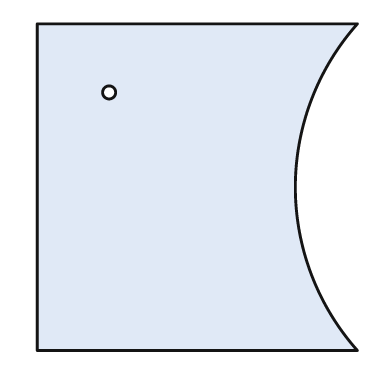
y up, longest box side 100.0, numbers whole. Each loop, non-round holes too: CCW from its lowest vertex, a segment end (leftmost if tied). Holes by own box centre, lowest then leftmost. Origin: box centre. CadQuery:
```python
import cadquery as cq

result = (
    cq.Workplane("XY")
    .moveTo(-49.0, -50.0)
    .lineTo(49.0, -50.0)
    .threePointArc((30.0, 0.0), (49.0, 50.0))
    .lineTo(-49.0, 50.0)
    .close()
    .moveTo(-27.0, 29.0)
    .circle(2.0)
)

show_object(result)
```